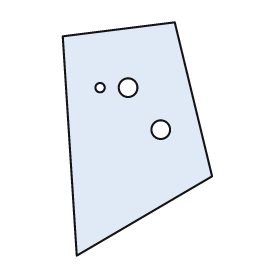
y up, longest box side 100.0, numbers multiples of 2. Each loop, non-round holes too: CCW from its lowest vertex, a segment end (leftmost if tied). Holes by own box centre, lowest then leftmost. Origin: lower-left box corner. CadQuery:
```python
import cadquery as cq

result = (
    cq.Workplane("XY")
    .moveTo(6.0, 0.0)
    .lineTo(64.0, 34.0)
    .lineTo(48.0, 100.0)
    .lineTo(0.0, 94.0)
    .close()
    .moveTo(42.0, 54.0)
    .circle(4.0)
    .moveTo(16.0, 72.0)
    .circle(2.0)
    .moveTo(28.0, 72.0)
    .circle(4.0)
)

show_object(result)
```